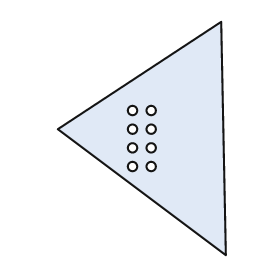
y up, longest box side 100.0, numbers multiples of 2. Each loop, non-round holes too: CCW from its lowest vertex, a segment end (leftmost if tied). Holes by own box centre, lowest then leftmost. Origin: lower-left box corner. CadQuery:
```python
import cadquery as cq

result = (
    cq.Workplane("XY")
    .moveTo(72.0, 0.0)
    .lineTo(70.0, 100.0)
    .lineTo(0.0, 54.0)
    .close()
    .moveTo(32.0, 38.0)
    .circle(2.0)
    .moveTo(40.0, 38.0)
    .circle(2.0)
    .moveTo(32.0, 46.0)
    .circle(2.0)
    .moveTo(40.0, 46.0)
    .circle(2.0)
    .moveTo(32.0, 54.0)
    .circle(2.0)
    .moveTo(40.0, 54.0)
    .circle(2.0)
    .moveTo(32.0, 62.0)
    .circle(2.0)
    .moveTo(40.0, 62.0)
    .circle(2.0)
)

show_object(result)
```